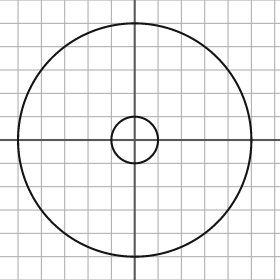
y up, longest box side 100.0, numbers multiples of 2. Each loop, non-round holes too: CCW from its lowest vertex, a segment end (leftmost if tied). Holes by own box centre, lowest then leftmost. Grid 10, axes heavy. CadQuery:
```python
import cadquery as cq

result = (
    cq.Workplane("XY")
    .moveTo(0.0, 0.0)
    .circle(50.0)
    .moveTo(0.0, 0.0)
    .circle(10.0)
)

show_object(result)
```